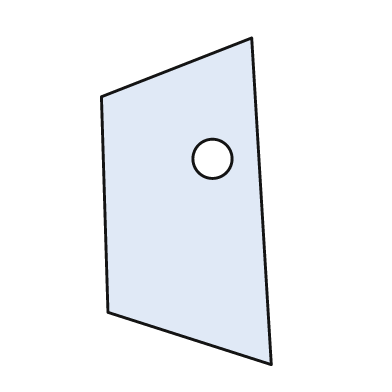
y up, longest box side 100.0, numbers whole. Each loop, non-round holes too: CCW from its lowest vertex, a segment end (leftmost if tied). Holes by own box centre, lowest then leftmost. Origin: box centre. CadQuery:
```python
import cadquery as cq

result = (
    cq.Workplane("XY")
    .moveTo(26.0, -50.0)
    .lineTo(20.0, 50.0)
    .lineTo(-26.0, 32.0)
    .lineTo(-24.0, -34.0)
    .close()
    .moveTo(8.0, 13.0)
    .circle(6.0)
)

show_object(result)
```